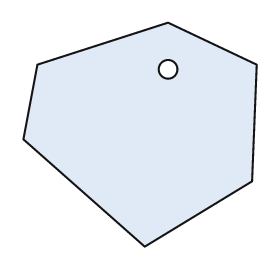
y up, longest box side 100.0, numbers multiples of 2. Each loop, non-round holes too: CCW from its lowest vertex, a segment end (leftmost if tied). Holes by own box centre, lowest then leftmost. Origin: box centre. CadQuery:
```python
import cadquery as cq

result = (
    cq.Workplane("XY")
    .moveTo(2.0, -48.0)
    .lineTo(48.0, -20.0)
    .lineTo(50.0, 30.0)
    .lineTo(12.0, 48.0)
    .lineTo(-44.0, 30.0)
    .lineTo(-50.0, -2.0)
    .close()
    .moveTo(12.0, 28.0)
    .circle(4.0)
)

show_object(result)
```